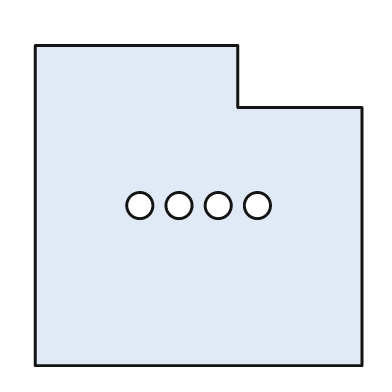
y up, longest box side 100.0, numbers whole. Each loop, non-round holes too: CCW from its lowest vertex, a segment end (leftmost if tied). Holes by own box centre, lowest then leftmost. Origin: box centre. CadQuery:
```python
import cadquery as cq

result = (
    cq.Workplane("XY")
    .moveTo(-50.0, -49.0)
    .lineTo(50.0, -49.0)
    .lineTo(50.0, 30.0)
    .lineTo(12.0, 30.0)
    .lineTo(12.0, 49.0)
    .lineTo(-50.0, 49.0)
    .close()
    .moveTo(-18.0, 0.0)
    .circle(4.0)
    .moveTo(-6.0, 0.0)
    .circle(4.0)
    .moveTo(6.0, 0.0)
    .circle(4.0)
    .moveTo(18.0, 0.0)
    .circle(4.0)
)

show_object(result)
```